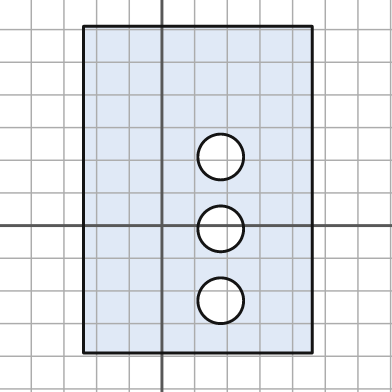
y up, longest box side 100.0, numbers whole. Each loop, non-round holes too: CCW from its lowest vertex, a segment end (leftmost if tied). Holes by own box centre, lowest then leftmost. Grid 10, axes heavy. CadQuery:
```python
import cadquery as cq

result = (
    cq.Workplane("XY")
    .moveTo(-24.0, -39.0)
    .lineTo(46.0, -39.0)
    .lineTo(46.0, 61.0)
    .lineTo(-24.0, 61.0)
    .close()
    .moveTo(18.0, -23.0)
    .circle(7.0)
    .moveTo(18.0, -1.0)
    .circle(7.0)
    .moveTo(18.0, 21.0)
    .circle(7.0)
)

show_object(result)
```